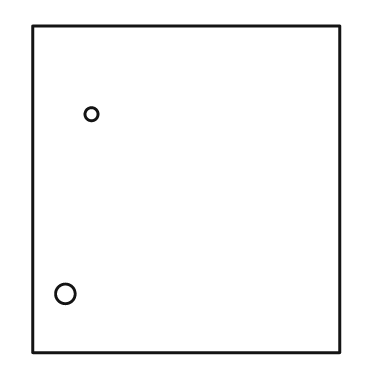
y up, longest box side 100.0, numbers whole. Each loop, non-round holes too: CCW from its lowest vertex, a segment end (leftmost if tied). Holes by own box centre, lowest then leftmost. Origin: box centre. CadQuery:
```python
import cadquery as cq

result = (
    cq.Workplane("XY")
    .moveTo(-47.0, -50.0)
    .lineTo(47.0, -50.0)
    .lineTo(47.0, 50.0)
    .lineTo(-47.0, 50.0)
    .close()
    .moveTo(-37.0, -32.0)
    .circle(3.0)
    .moveTo(-29.0, 23.0)
    .circle(2.0)
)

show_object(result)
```